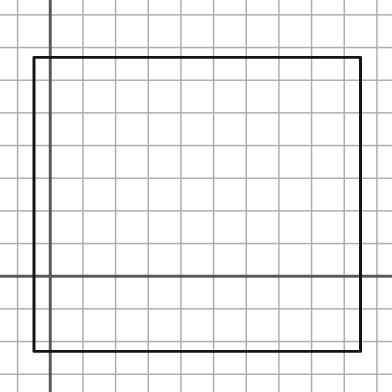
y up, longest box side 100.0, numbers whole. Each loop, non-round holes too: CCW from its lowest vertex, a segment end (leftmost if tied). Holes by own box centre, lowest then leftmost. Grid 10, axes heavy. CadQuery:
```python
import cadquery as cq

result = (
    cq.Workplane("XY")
    .moveTo(-5.0, -23.0)
    .lineTo(95.0, -23.0)
    .lineTo(95.0, 67.0)
    .lineTo(-5.0, 67.0)
    .close()
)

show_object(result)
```